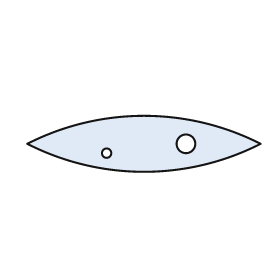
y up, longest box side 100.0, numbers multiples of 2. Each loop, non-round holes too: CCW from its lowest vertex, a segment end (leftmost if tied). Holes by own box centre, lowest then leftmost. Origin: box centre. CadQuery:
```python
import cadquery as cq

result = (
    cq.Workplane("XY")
    .moveTo(-50.0, 0.0)
    .threePointArc((0.0, -12.0), (50.0, 0.0))
    .threePointArc((0.0, 12.0), (-50.0, 0.0))
    .close()
    .moveTo(-16.0, -4.0)
    .circle(2.0)
    .moveTo(18.0, 0.0)
    .circle(4.0)
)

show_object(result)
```